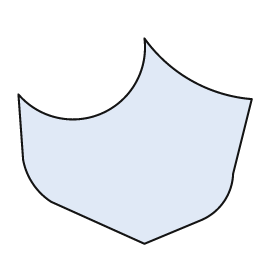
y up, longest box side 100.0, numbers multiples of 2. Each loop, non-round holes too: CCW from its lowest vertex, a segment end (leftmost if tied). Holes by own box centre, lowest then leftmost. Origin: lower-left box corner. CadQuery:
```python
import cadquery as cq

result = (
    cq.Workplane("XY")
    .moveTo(54.0, 0.0)
    .lineTo(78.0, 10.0)
    .threePointArc((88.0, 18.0), (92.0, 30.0))
    .lineTo(100.0, 62.0)
    .threePointArc((74.0, 70.0), (54.0, 88.0))
    .threePointArc((36.0, 56.0), (0.0, 64.0))
    .lineTo(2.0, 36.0)
    .threePointArc((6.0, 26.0), (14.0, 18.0))
    .close()
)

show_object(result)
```